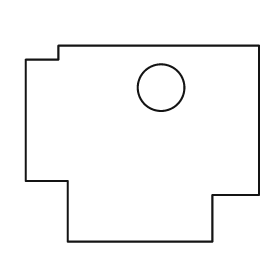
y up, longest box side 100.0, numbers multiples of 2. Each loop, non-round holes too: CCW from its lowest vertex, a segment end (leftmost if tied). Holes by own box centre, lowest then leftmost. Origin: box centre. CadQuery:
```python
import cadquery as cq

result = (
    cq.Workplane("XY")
    .moveTo(-32.0, -42.0)
    .lineTo(30.0, -42.0)
    .lineTo(30.0, -22.0)
    .lineTo(50.0, -22.0)
    .lineTo(50.0, 42.0)
    .lineTo(-36.0, 42.0)
    .lineTo(-36.0, 36.0)
    .lineTo(-50.0, 36.0)
    .lineTo(-50.0, -16.0)
    .lineTo(-32.0, -16.0)
    .close()
    .moveTo(8.0, 24.0)
    .circle(10.0)
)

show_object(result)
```